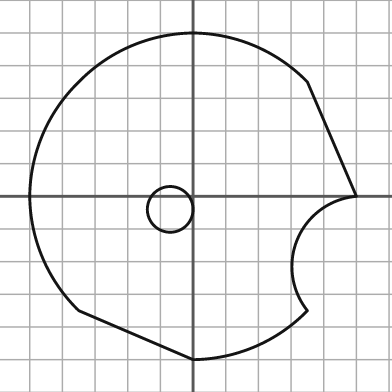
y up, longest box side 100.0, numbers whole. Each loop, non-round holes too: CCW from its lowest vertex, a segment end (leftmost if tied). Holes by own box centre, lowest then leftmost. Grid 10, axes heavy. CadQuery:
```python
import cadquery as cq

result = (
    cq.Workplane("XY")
    .moveTo(0.0, -50.0)
    .threePointArc((19.0, -46.0), (35.0, -35.0))
    .threePointArc((32.0, -13.0), (50.0, 0.0))
    .lineTo(35.0, 35.0)
    .threePointArc((19.0, 46.0), (0.0, 50.0))
    .threePointArc((-19.0, 46.0), (-35.0, 35.0))
    .threePointArc((-46.0, 19.0), (-50.0, 0.0))
    .threePointArc((-46.0, -19.0), (-35.0, -35.0))
    .close()
    .moveTo(-7.0, -4.0)
    .circle(7.0)
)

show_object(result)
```